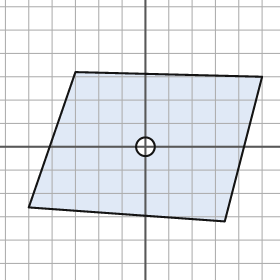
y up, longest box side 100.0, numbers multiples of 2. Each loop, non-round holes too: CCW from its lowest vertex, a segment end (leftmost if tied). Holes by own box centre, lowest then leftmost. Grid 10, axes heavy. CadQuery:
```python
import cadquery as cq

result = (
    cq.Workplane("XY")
    .moveTo(34.0, -32.0)
    .lineTo(50.0, 30.0)
    .lineTo(-30.0, 32.0)
    .lineTo(-50.0, -26.0)
    .close()
    .moveTo(0.0, 0.0)
    .circle(4.0)
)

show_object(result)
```